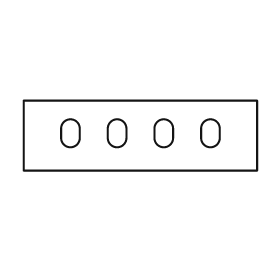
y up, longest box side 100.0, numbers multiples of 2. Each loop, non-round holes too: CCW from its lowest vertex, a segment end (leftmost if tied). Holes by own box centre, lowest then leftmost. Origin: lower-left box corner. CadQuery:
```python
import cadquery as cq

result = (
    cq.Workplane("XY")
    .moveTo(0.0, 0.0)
    .lineTo(100.0, 0.0)
    .lineTo(100.0, 30.0)
    .lineTo(0.0, 30.0)
    .close()
    .moveTo(16.0, 14.0)
    .threePointArc((20.0, 10.0), (24.0, 14.0))
    .lineTo(24.0, 18.0)
    .threePointArc((20.0, 22.0), (16.0, 18.0))
    .close()
    .moveTo(36.0, 14.0)
    .threePointArc((40.0, 10.0), (44.0, 14.0))
    .lineTo(44.0, 18.0)
    .threePointArc((40.0, 22.0), (36.0, 18.0))
    .close()
    .moveTo(56.0, 14.0)
    .threePointArc((60.0, 10.0), (64.0, 14.0))
    .lineTo(64.0, 18.0)
    .threePointArc((60.0, 22.0), (56.0, 18.0))
    .close()
    .moveTo(76.0, 14.0)
    .threePointArc((80.0, 10.0), (84.0, 14.0))
    .lineTo(84.0, 18.0)
    .threePointArc((80.0, 22.0), (76.0, 18.0))
    .close()
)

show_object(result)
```